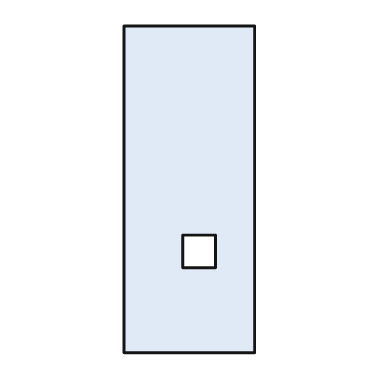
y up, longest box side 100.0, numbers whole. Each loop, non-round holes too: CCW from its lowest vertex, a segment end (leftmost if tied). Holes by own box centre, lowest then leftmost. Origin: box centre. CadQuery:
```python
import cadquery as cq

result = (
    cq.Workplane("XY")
    .moveTo(-20.0, -50.0)
    .lineTo(20.0, -50.0)
    .lineTo(20.0, 50.0)
    .lineTo(-20.0, 50.0)
    .close()
    .moveTo(-2.0, -24.0)
    .lineTo(8.0, -24.0)
    .lineTo(8.0, -14.0)
    .lineTo(-2.0, -14.0)
    .close()
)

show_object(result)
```